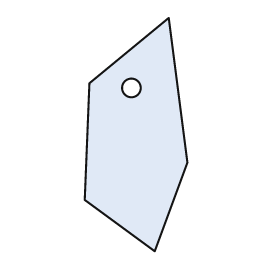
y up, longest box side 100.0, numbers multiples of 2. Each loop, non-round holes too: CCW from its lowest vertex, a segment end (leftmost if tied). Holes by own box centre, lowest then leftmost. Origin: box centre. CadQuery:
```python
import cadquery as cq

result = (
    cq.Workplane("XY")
    .moveTo(8.0, -50.0)
    .lineTo(22.0, -12.0)
    .lineTo(14.0, 50.0)
    .lineTo(-20.0, 22.0)
    .lineTo(-22.0, -28.0)
    .close()
    .moveTo(-2.0, 20.0)
    .circle(4.0)
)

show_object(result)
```